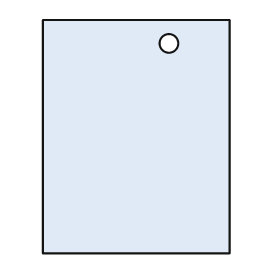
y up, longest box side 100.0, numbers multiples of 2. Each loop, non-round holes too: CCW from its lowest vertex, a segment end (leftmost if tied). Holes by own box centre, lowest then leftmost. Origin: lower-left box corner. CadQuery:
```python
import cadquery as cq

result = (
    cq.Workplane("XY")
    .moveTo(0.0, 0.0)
    .lineTo(80.0, 0.0)
    .lineTo(80.0, 100.0)
    .lineTo(0.0, 100.0)
    .close()
    .moveTo(54.0, 90.0)
    .circle(4.0)
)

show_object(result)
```